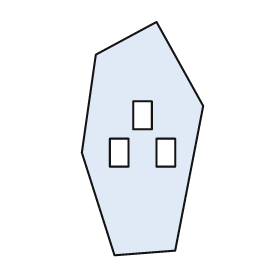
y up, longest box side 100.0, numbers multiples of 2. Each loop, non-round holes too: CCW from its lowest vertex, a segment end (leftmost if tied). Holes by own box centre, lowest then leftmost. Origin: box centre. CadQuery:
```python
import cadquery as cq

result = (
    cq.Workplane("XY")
    .moveTo(-12.0, -50.0)
    .lineTo(14.0, -48.0)
    .lineTo(26.0, 14.0)
    .lineTo(6.0, 50.0)
    .lineTo(-20.0, 36.0)
    .lineTo(-26.0, -6.0)
    .close()
    .moveTo(-14.0, -12.0)
    .lineTo(-6.0, -12.0)
    .lineTo(-6.0, 0.0)
    .lineTo(-14.0, 0.0)
    .close()
    .moveTo(6.0, -12.0)
    .lineTo(14.0, -12.0)
    .lineTo(14.0, 0.0)
    .lineTo(6.0, 0.0)
    .close()
    .moveTo(-4.0, 4.0)
    .lineTo(4.0, 4.0)
    .lineTo(4.0, 16.0)
    .lineTo(-4.0, 16.0)
    .close()
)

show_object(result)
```